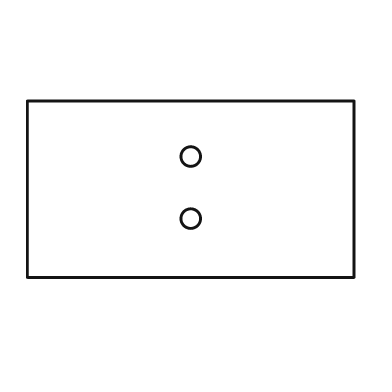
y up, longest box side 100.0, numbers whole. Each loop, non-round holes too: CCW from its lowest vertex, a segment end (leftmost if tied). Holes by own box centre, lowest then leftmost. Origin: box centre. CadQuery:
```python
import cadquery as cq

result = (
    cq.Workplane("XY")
    .moveTo(-50.0, -27.0)
    .lineTo(50.0, -27.0)
    .lineTo(50.0, 27.0)
    .lineTo(-50.0, 27.0)
    .close()
    .moveTo(0.0, -9.0)
    .circle(3.0)
    .moveTo(0.0, 10.0)
    .circle(3.0)
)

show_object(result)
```